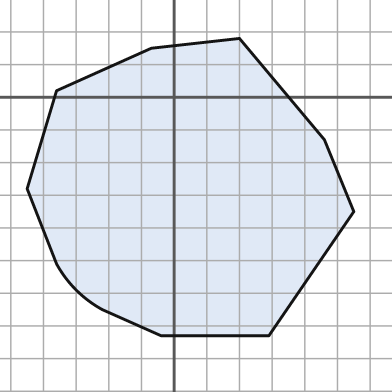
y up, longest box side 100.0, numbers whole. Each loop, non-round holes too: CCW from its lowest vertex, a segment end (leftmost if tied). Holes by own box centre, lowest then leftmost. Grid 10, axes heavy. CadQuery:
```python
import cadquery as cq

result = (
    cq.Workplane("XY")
    .moveTo(-4.0, -73.0)
    .lineTo(29.0, -73.0)
    .lineTo(55.0, -35.0)
    .lineTo(46.0, -13.0)
    .lineTo(20.0, 18.0)
    .lineTo(-7.0, 15.0)
    .lineTo(-36.0, 2.0)
    .lineTo(-45.0, -28.0)
    .lineTo(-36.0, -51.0)
    .threePointArc((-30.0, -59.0), (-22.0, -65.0))
    .close()
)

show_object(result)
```